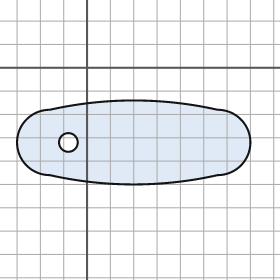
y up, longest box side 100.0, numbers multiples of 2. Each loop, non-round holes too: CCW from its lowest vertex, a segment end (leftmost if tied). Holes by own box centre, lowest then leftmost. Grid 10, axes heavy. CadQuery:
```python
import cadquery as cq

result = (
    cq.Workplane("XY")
    .moveTo(-16.0, -46.0)
    .threePointArc((20.0, -50.0), (56.0, -46.0))
    .threePointArc((70.0, -32.0), (56.0, -18.0))
    .threePointArc((20.0, -14.0), (-16.0, -18.0))
    .threePointArc((-30.0, -32.0), (-16.0, -46.0))
    .close()
    .moveTo(-8.0, -32.0)
    .circle(4.0)
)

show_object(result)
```